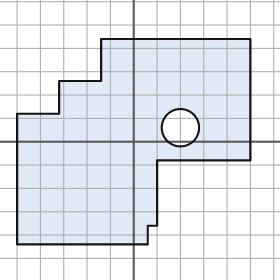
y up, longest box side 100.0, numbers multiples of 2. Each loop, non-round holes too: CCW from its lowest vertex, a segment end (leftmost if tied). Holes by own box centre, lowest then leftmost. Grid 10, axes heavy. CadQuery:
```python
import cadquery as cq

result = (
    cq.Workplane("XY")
    .moveTo(-50.0, -44.0)
    .lineTo(6.0, -44.0)
    .lineTo(6.0, -36.0)
    .lineTo(10.0, -36.0)
    .lineTo(10.0, -8.0)
    .lineTo(50.0, -8.0)
    .lineTo(50.0, 44.0)
    .lineTo(-14.0, 44.0)
    .lineTo(-14.0, 26.0)
    .lineTo(-32.0, 26.0)
    .lineTo(-32.0, 12.0)
    .lineTo(-50.0, 12.0)
    .close()
    .moveTo(20.0, 6.0)
    .circle(8.0)
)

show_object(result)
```